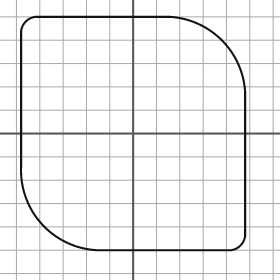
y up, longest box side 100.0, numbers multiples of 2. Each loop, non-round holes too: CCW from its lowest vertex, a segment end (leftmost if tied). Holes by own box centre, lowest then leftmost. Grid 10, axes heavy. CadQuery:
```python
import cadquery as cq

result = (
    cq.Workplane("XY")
    .moveTo(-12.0, -50.0)
    .lineTo(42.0, -50.0)
    .threePointArc((46.0, -48.0), (48.0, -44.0))
    .lineTo(48.0, 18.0)
    .threePointArc((38.0, 40.0), (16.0, 50.0))
    .lineTo(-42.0, 50.0)
    .threePointArc((-46.0, 48.0), (-48.0, 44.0))
    .lineTo(-48.0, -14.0)
    .threePointArc((-38.0, -40.0), (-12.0, -50.0))
    .close()
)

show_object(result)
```